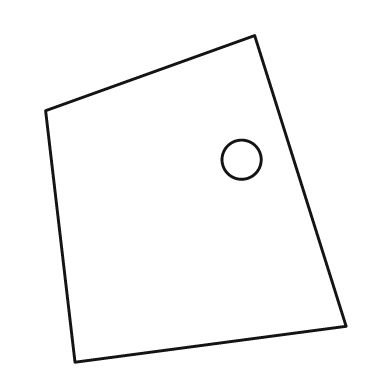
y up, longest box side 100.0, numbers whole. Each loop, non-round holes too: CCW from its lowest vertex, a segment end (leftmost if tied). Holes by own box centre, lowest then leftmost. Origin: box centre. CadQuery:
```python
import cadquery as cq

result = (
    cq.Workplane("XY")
    .moveTo(-37.0, -50.0)
    .lineTo(46.0, -39.0)
    .lineTo(18.0, 50.0)
    .lineTo(-46.0, 27.0)
    .close()
    .moveTo(14.0, 12.0)
    .circle(6.0)
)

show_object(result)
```